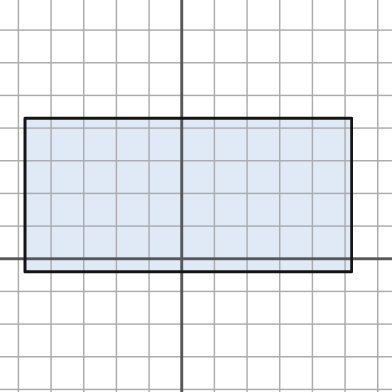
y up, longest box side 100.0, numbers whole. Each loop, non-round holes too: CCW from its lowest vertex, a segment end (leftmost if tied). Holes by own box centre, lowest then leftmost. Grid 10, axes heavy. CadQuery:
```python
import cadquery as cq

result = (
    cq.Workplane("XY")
    .moveTo(-48.0, -4.0)
    .lineTo(52.0, -4.0)
    .lineTo(52.0, 43.0)
    .lineTo(-48.0, 43.0)
    .close()
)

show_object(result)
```